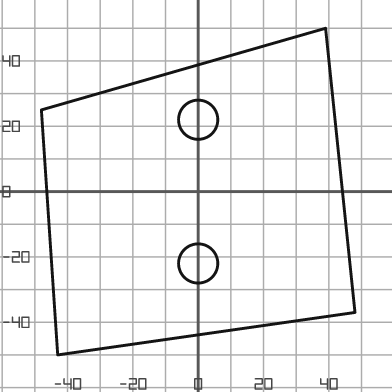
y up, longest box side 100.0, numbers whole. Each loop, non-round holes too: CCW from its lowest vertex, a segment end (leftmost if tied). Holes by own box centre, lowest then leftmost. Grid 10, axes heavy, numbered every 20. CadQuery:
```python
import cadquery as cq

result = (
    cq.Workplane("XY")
    .moveTo(-43.0, -50.0)
    .lineTo(48.0, -37.0)
    .lineTo(39.0, 50.0)
    .lineTo(-48.0, 25.0)
    .close()
    .moveTo(0.0, -22.0)
    .circle(6.0)
    .moveTo(0.0, 22.0)
    .circle(6.0)
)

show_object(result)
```